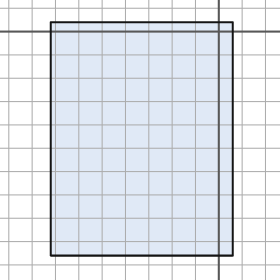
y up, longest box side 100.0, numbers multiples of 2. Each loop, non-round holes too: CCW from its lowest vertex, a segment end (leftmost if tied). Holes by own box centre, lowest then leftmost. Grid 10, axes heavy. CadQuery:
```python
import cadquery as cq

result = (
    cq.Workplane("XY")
    .moveTo(-72.0, -96.0)
    .lineTo(6.0, -96.0)
    .lineTo(6.0, 4.0)
    .lineTo(-72.0, 4.0)
    .close()
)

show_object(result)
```